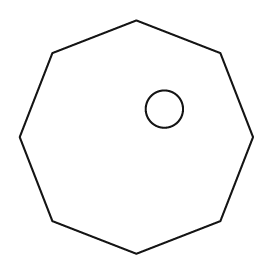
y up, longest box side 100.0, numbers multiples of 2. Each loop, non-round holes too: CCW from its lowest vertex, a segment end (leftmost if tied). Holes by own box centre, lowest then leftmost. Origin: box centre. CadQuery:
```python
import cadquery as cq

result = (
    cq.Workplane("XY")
    .moveTo(0.0, -50.0)
    .lineTo(36.0, -36.0)
    .lineTo(50.0, 0.0)
    .lineTo(36.0, 36.0)
    .lineTo(0.0, 50.0)
    .lineTo(-36.0, 36.0)
    .lineTo(-50.0, 0.0)
    .lineTo(-36.0, -36.0)
    .close()
    .moveTo(12.0, 12.0)
    .circle(8.0)
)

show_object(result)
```